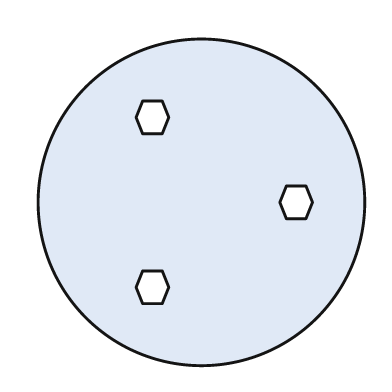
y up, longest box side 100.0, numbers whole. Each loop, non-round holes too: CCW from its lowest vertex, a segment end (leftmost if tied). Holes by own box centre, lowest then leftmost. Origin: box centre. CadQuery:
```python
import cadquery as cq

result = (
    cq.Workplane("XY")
    .moveTo(0.0, 0.0)
    .circle(50.0)
    .moveTo(-18.0, -31.0)
    .lineTo(-12.0, -31.0)
    .lineTo(-10.0, -26.0)
    .lineTo(-12.0, -21.0)
    .lineTo(-18.0, -21.0)
    .lineTo(-20.0, -26.0)
    .close()
    .moveTo(26.0, -5.0)
    .lineTo(32.0, -5.0)
    .lineTo(34.0, 0.0)
    .lineTo(32.0, 5.0)
    .lineTo(26.0, 5.0)
    .lineTo(24.0, 0.0)
    .close()
    .moveTo(-18.0, 21.0)
    .lineTo(-12.0, 21.0)
    .lineTo(-10.0, 26.0)
    .lineTo(-12.0, 31.0)
    .lineTo(-18.0, 31.0)
    .lineTo(-20.0, 26.0)
    .close()
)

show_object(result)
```